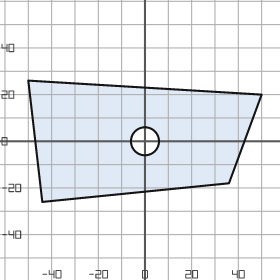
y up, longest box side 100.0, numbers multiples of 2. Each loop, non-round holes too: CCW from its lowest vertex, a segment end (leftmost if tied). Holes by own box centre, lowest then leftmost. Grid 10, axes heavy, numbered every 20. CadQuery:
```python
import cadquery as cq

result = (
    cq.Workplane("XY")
    .moveTo(-44.0, -26.0)
    .lineTo(36.0, -18.0)
    .lineTo(50.0, 20.0)
    .lineTo(-50.0, 26.0)
    .close()
    .moveTo(0.0, 0.0)
    .circle(6.0)
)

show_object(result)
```